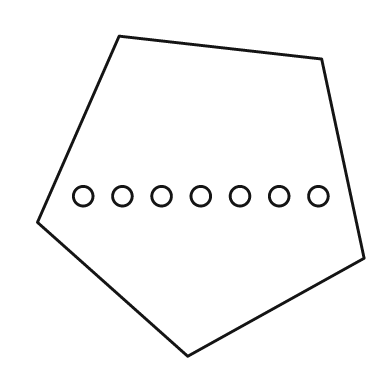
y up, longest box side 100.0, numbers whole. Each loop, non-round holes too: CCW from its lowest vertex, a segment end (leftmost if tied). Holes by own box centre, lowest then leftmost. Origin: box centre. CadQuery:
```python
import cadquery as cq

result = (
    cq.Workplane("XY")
    .moveTo(-4.0, -49.0)
    .lineTo(50.0, -19.0)
    .lineTo(37.0, 42.0)
    .lineTo(-25.0, 49.0)
    .lineTo(-50.0, -8.0)
    .close()
    .moveTo(-36.0, 0.0)
    .circle(3.0)
    .moveTo(-24.0, 0.0)
    .circle(3.0)
    .moveTo(-12.0, 0.0)
    .circle(3.0)
    .moveTo(0.0, 0.0)
    .circle(3.0)
    .moveTo(12.0, 0.0)
    .circle(3.0)
    .moveTo(24.0, 0.0)
    .circle(3.0)
    .moveTo(36.0, 0.0)
    .circle(3.0)
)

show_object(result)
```